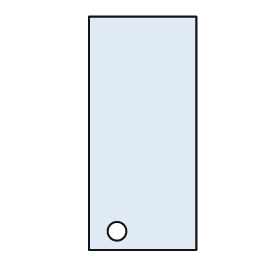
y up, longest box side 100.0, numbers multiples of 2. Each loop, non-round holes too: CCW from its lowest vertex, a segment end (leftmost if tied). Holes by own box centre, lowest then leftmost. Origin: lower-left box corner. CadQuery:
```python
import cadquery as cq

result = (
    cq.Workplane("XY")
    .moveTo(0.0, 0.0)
    .lineTo(46.0, 0.0)
    .lineTo(46.0, 100.0)
    .lineTo(0.0, 100.0)
    .close()
    .moveTo(12.0, 8.0)
    .circle(4.0)
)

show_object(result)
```